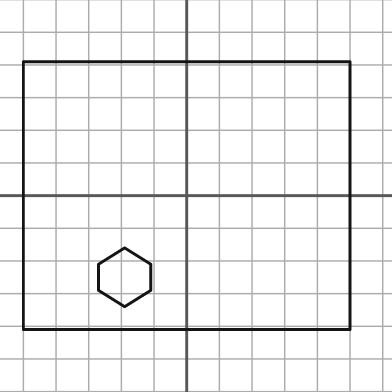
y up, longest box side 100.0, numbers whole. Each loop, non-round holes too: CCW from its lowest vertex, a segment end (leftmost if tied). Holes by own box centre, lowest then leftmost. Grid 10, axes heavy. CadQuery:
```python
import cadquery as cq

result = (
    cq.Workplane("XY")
    .moveTo(-50.0, -41.0)
    .lineTo(50.0, -41.0)
    .lineTo(50.0, 41.0)
    .lineTo(-50.0, 41.0)
    .close()
    .moveTo(-19.0, -34.0)
    .lineTo(-11.0, -29.0)
    .lineTo(-11.0, -21.0)
    .lineTo(-19.0, -16.0)
    .lineTo(-27.0, -21.0)
    .lineTo(-27.0, -29.0)
    .close()
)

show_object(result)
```